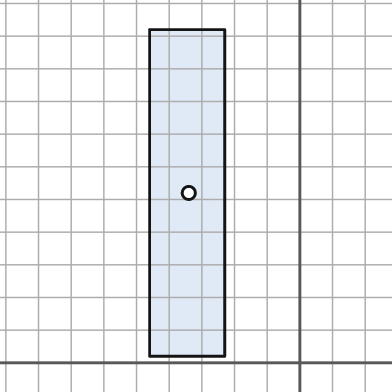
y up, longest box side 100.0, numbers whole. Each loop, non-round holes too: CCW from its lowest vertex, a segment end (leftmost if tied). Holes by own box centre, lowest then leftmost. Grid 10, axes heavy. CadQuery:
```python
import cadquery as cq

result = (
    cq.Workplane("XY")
    .moveTo(-46.0, 2.0)
    .lineTo(-23.0, 2.0)
    .lineTo(-23.0, 102.0)
    .lineTo(-46.0, 102.0)
    .close()
    .moveTo(-34.0, 52.0)
    .circle(2.0)
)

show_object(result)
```